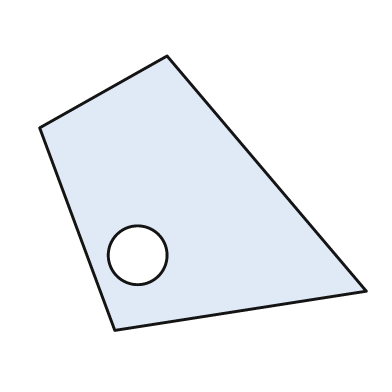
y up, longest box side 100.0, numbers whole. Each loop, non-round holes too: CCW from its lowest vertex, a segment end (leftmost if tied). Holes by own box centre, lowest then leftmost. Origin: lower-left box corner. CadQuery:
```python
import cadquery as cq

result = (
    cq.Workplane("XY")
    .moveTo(23.0, 0.0)
    .lineTo(100.0, 12.0)
    .lineTo(39.0, 84.0)
    .lineTo(0.0, 62.0)
    .close()
    .moveTo(30.0, 23.0)
    .circle(9.0)
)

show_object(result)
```